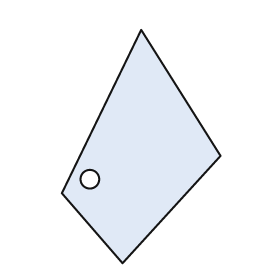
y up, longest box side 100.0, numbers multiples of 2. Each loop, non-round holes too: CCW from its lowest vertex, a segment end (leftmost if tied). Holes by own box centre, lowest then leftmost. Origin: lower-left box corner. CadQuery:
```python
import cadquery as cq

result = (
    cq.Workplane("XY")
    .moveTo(26.0, 0.0)
    .lineTo(68.0, 46.0)
    .lineTo(34.0, 100.0)
    .lineTo(0.0, 30.0)
    .close()
    .moveTo(12.0, 36.0)
    .circle(4.0)
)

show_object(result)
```